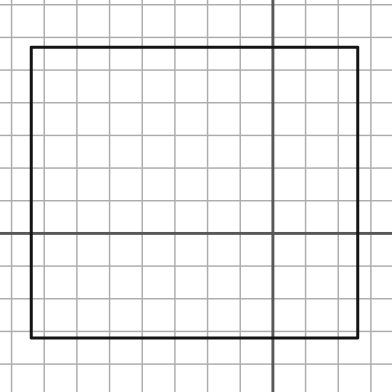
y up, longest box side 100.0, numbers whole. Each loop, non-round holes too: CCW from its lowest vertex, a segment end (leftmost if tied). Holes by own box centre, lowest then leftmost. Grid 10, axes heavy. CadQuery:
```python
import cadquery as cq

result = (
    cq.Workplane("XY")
    .moveTo(-74.0, -32.0)
    .lineTo(26.0, -32.0)
    .lineTo(26.0, 57.0)
    .lineTo(-74.0, 57.0)
    .close()
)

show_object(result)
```